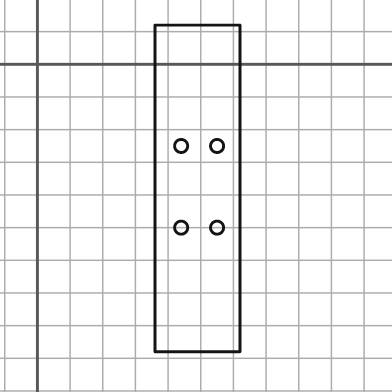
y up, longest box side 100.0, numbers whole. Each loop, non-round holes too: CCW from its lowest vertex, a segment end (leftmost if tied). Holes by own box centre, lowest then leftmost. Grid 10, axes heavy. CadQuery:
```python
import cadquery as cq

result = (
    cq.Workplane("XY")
    .moveTo(36.0, -88.0)
    .lineTo(62.0, -88.0)
    .lineTo(62.0, 12.0)
    .lineTo(36.0, 12.0)
    .close()
    .moveTo(44.0, -50.0)
    .circle(2.0)
    .moveTo(55.0, -50.0)
    .circle(2.0)
    .moveTo(44.0, -25.0)
    .circle(2.0)
    .moveTo(55.0, -25.0)
    .circle(2.0)
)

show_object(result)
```